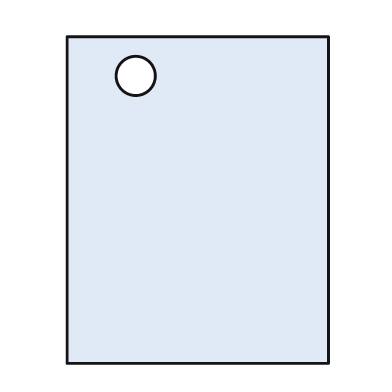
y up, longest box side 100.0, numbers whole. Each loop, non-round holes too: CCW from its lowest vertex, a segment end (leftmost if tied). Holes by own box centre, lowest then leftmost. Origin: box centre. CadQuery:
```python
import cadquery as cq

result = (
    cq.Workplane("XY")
    .moveTo(-40.0, -50.0)
    .lineTo(40.0, -50.0)
    .lineTo(40.0, 50.0)
    .lineTo(-40.0, 50.0)
    .close()
    .moveTo(-19.0, 38.0)
    .circle(6.0)
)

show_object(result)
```